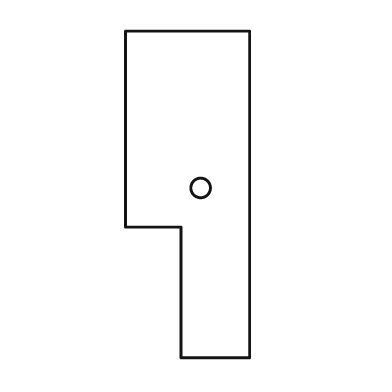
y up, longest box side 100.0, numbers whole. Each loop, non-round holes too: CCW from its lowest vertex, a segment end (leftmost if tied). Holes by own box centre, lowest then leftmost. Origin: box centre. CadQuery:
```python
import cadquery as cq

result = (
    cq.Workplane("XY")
    .moveTo(-2.0, -50.0)
    .lineTo(19.0, -50.0)
    .lineTo(19.0, 50.0)
    .lineTo(-19.0, 50.0)
    .lineTo(-19.0, -10.0)
    .lineTo(-2.0, -10.0)
    .close()
    .moveTo(4.0, 2.0)
    .circle(3.0)
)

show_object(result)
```